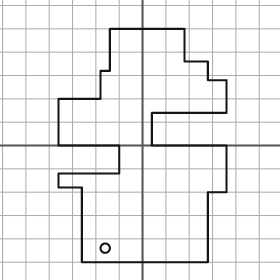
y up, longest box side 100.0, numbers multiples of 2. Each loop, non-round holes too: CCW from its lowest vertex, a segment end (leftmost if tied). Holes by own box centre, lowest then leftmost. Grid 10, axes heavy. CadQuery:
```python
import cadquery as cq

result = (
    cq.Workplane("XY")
    .moveTo(-26.0, -50.0)
    .lineTo(28.0, -50.0)
    .lineTo(28.0, -20.0)
    .lineTo(36.0, -20.0)
    .lineTo(36.0, 0.0)
    .lineTo(4.0, 0.0)
    .lineTo(4.0, 14.0)
    .lineTo(36.0, 14.0)
    .lineTo(36.0, 28.0)
    .lineTo(28.0, 28.0)
    .lineTo(28.0, 36.0)
    .lineTo(18.0, 36.0)
    .lineTo(18.0, 50.0)
    .lineTo(-14.0, 50.0)
    .lineTo(-14.0, 32.0)
    .lineTo(-18.0, 32.0)
    .lineTo(-18.0, 20.0)
    .lineTo(-36.0, 20.0)
    .lineTo(-36.0, 0.0)
    .lineTo(-10.0, 0.0)
    .lineTo(-10.0, -12.0)
    .lineTo(-36.0, -12.0)
    .lineTo(-36.0, -18.0)
    .lineTo(-26.0, -18.0)
    .close()
    .moveTo(-16.0, -44.0)
    .circle(2.0)
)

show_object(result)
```